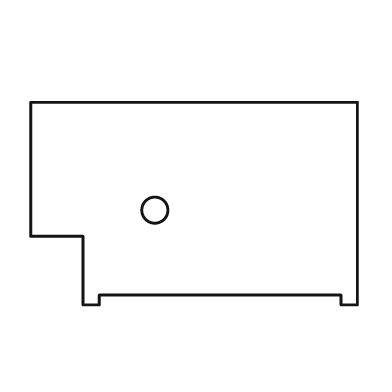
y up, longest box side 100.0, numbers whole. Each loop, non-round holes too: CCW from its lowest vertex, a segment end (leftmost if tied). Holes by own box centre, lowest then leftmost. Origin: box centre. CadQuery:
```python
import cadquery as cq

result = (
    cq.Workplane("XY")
    .moveTo(-34.0, -31.0)
    .lineTo(-29.0, -31.0)
    .lineTo(-29.0, -28.0)
    .lineTo(45.0, -28.0)
    .lineTo(45.0, -31.0)
    .lineTo(50.0, -31.0)
    .lineTo(50.0, 31.0)
    .lineTo(-50.0, 31.0)
    .lineTo(-50.0, -10.0)
    .lineTo(-34.0, -10.0)
    .close()
    .moveTo(-12.0, -2.0)
    .circle(4.0)
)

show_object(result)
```